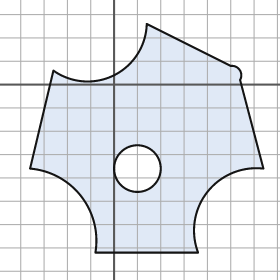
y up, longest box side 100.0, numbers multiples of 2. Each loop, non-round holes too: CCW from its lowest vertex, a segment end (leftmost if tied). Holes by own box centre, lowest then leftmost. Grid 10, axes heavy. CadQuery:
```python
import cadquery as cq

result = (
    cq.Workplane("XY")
    .moveTo(-8.0, -72.0)
    .lineTo(36.0, -72.0)
    .threePointArc((40.0, -46.0), (64.0, -36.0))
    .lineTo(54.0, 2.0)
    .threePointArc((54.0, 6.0), (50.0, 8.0))
    .lineTo(14.0, 26.0)
    .threePointArc((0.0, 4.0), (-26.0, 6.0))
    .lineTo(-36.0, -36.0)
    .threePointArc((-14.0, -48.0), (-8.0, -72.0))
    .close()
    .moveTo(10.0, -36.0)
    .circle(10.0)
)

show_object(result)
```